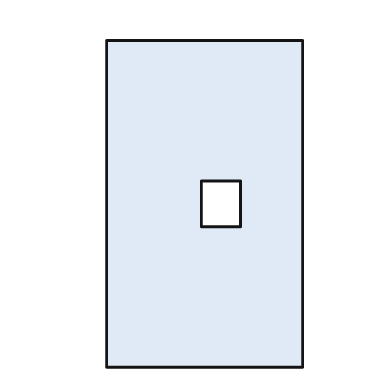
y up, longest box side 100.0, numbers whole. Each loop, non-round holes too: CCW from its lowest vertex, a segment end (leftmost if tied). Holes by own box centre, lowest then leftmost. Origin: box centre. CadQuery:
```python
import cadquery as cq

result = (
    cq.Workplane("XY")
    .moveTo(-30.0, -50.0)
    .lineTo(30.0, -50.0)
    .lineTo(30.0, 50.0)
    .lineTo(-30.0, 50.0)
    .close()
    .moveTo(-1.0, -7.0)
    .lineTo(11.0, -7.0)
    .lineTo(11.0, 7.0)
    .lineTo(-1.0, 7.0)
    .close()
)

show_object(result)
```